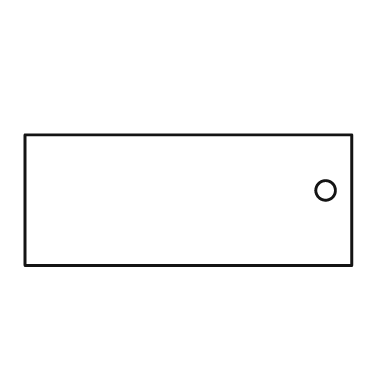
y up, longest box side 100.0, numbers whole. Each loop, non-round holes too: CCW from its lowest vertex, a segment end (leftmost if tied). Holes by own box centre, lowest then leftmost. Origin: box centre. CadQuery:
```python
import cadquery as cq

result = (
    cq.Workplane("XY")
    .moveTo(-50.0, -20.0)
    .lineTo(50.0, -20.0)
    .lineTo(50.0, 20.0)
    .lineTo(-50.0, 20.0)
    .close()
    .moveTo(42.0, 3.0)
    .circle(3.0)
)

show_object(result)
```